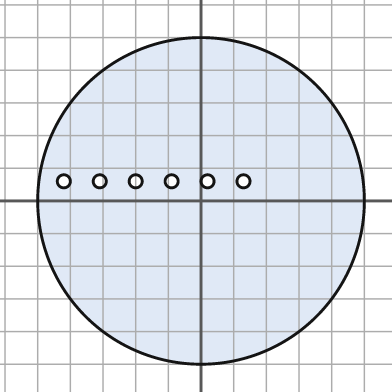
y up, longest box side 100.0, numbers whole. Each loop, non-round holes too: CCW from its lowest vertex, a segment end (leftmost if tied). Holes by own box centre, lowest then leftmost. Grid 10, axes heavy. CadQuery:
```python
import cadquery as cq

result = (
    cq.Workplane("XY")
    .moveTo(0.0, 0.0)
    .circle(50.0)
    .moveTo(-42.0, 6.0)
    .circle(2.0)
    .moveTo(-31.0, 6.0)
    .circle(2.0)
    .moveTo(-20.0, 6.0)
    .circle(2.0)
    .moveTo(-9.0, 6.0)
    .circle(2.0)
    .moveTo(2.0, 6.0)
    .circle(2.0)
    .moveTo(13.0, 6.0)
    .circle(2.0)
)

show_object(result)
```